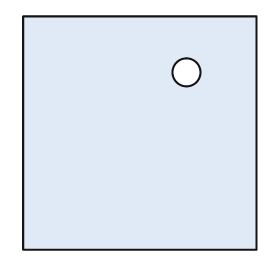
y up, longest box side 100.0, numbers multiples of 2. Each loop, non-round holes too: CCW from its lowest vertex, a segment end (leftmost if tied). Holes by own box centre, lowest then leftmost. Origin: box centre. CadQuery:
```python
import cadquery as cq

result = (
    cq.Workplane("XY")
    .moveTo(-50.0, -50.0)
    .lineTo(50.0, -50.0)
    .lineTo(50.0, 50.0)
    .lineTo(-50.0, 50.0)
    .close()
    .moveTo(20.0, 26.0)
    .circle(6.0)
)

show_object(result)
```